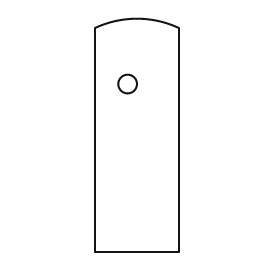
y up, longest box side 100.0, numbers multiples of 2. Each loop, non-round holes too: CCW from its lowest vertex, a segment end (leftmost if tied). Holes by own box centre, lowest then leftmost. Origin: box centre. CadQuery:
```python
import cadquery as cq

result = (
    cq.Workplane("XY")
    .moveTo(-18.0, -50.0)
    .lineTo(18.0, -50.0)
    .lineTo(18.0, 46.0)
    .threePointArc((0.0, 50.0), (-18.0, 46.0))
    .close()
    .moveTo(-4.0, 22.0)
    .circle(4.0)
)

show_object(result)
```